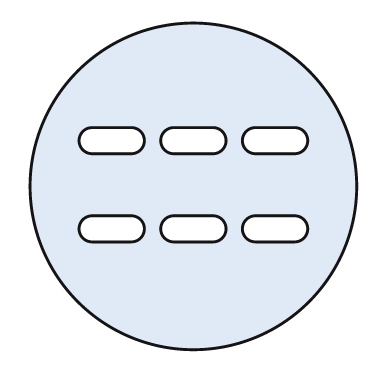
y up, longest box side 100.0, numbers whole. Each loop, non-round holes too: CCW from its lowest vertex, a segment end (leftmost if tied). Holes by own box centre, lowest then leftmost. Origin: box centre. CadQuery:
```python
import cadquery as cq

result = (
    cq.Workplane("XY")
    .moveTo(0.0, 0.0)
    .circle(50.0)
    .moveTo(-31.0, -17.0)
    .lineTo(-19.0, -17.0)
    .threePointArc((-15.0, -13.0), (-19.0, -9.0))
    .lineTo(-31.0, -9.0)
    .threePointArc((-35.0, -13.0), (-31.0, -17.0))
    .close()
    .moveTo(-6.0, -17.0)
    .lineTo(6.0, -17.0)
    .threePointArc((10.0, -13.0), (6.0, -9.0))
    .lineTo(-6.0, -9.0)
    .threePointArc((-10.0, -13.0), (-6.0, -17.0))
    .close()
    .moveTo(19.0, -17.0)
    .lineTo(31.0, -17.0)
    .threePointArc((35.0, -13.0), (31.0, -9.0))
    .lineTo(19.0, -9.0)
    .threePointArc((15.0, -13.0), (19.0, -17.0))
    .close()
    .moveTo(-31.0, 10.0)
    .lineTo(-19.0, 10.0)
    .threePointArc((-15.0, 14.0), (-19.0, 18.0))
    .lineTo(-31.0, 18.0)
    .threePointArc((-35.0, 14.0), (-31.0, 10.0))
    .close()
    .moveTo(-6.0, 10.0)
    .lineTo(6.0, 10.0)
    .threePointArc((10.0, 14.0), (6.0, 18.0))
    .lineTo(-6.0, 18.0)
    .threePointArc((-10.0, 14.0), (-6.0, 10.0))
    .close()
    .moveTo(19.0, 10.0)
    .lineTo(31.0, 10.0)
    .threePointArc((35.0, 14.0), (31.0, 18.0))
    .lineTo(19.0, 18.0)
    .threePointArc((15.0, 14.0), (19.0, 10.0))
    .close()
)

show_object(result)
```